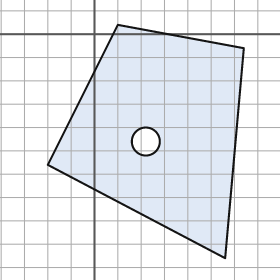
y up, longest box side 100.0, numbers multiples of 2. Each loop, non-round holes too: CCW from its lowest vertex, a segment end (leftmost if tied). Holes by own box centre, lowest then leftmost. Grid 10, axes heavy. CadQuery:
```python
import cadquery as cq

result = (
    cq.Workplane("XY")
    .moveTo(56.0, -96.0)
    .lineTo(64.0, -6.0)
    .lineTo(10.0, 4.0)
    .lineTo(-20.0, -56.0)
    .close()
    .moveTo(22.0, -46.0)
    .circle(6.0)
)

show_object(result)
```